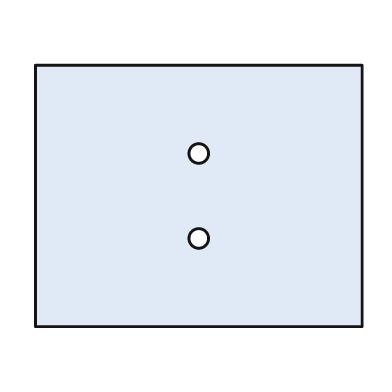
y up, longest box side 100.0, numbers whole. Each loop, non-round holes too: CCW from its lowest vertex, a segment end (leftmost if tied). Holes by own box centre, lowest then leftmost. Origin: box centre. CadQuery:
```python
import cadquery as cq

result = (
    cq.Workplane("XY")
    .moveTo(-50.0, -40.0)
    .lineTo(50.0, -40.0)
    .lineTo(50.0, 40.0)
    .lineTo(-50.0, 40.0)
    .close()
    .moveTo(0.0, -13.0)
    .circle(3.0)
    .moveTo(0.0, 13.0)
    .circle(3.0)
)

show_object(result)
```